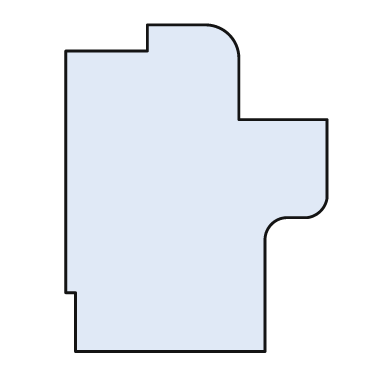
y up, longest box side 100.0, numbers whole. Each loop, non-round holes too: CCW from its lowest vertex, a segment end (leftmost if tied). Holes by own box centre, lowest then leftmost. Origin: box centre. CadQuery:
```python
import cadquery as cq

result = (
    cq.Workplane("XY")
    .moveTo(-37.0, -50.0)
    .lineTo(21.0, -50.0)
    .lineTo(21.0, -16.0)
    .threePointArc((23.0, -11.0), (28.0, -9.0))
    .lineTo(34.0, -9.0)
    .threePointArc((38.0, -7.0), (40.0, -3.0))
    .lineTo(40.0, 21.0)
    .lineTo(13.0, 21.0)
    .lineTo(13.0, 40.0)
    .threePointArc((10.0, 47.0), (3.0, 50.0))
    .lineTo(-15.0, 50.0)
    .lineTo(-15.0, 42.0)
    .lineTo(-40.0, 42.0)
    .lineTo(-40.0, -32.0)
    .lineTo(-37.0, -32.0)
    .close()
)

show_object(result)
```